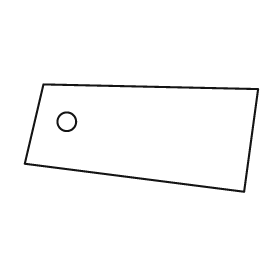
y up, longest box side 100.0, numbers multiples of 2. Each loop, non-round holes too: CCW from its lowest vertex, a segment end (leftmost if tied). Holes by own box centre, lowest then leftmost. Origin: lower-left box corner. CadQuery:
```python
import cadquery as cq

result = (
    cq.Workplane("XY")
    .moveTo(94.0, 0.0)
    .lineTo(100.0, 44.0)
    .lineTo(8.0, 46.0)
    .lineTo(0.0, 12.0)
    .close()
    .moveTo(18.0, 30.0)
    .circle(4.0)
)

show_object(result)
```